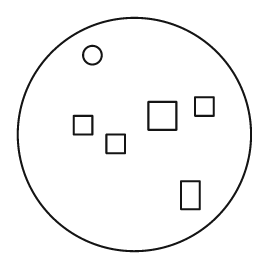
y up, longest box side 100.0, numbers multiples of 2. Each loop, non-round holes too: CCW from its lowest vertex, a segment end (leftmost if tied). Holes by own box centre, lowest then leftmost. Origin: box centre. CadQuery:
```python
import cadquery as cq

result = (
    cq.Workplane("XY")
    .moveTo(0.0, 0.0)
    .circle(50.0)
    .moveTo(20.0, -32.0)
    .lineTo(28.0, -32.0)
    .lineTo(28.0, -20.0)
    .lineTo(20.0, -20.0)
    .close()
    .moveTo(-12.0, -8.0)
    .lineTo(-4.0, -8.0)
    .lineTo(-4.0, 0.0)
    .lineTo(-12.0, 0.0)
    .close()
    .moveTo(-26.0, 0.0)
    .lineTo(-18.0, 0.0)
    .lineTo(-18.0, 8.0)
    .lineTo(-26.0, 8.0)
    .close()
    .moveTo(6.0, 2.0)
    .lineTo(18.0, 2.0)
    .lineTo(18.0, 14.0)
    .lineTo(6.0, 14.0)
    .close()
    .moveTo(26.0, 8.0)
    .lineTo(34.0, 8.0)
    .lineTo(34.0, 16.0)
    .lineTo(26.0, 16.0)
    .close()
    .moveTo(-18.0, 34.0)
    .circle(4.0)
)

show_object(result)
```